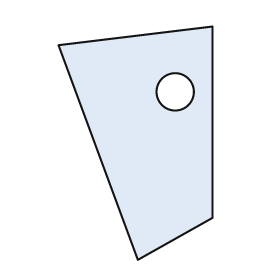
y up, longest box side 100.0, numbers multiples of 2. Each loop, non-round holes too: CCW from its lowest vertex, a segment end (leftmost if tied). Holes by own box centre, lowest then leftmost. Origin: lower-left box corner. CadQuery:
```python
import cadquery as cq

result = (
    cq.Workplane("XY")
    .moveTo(34.0, 0.0)
    .lineTo(66.0, 18.0)
    .lineTo(66.0, 100.0)
    .lineTo(0.0, 92.0)
    .close()
    .moveTo(50.0, 72.0)
    .circle(8.0)
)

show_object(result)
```